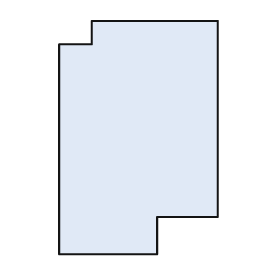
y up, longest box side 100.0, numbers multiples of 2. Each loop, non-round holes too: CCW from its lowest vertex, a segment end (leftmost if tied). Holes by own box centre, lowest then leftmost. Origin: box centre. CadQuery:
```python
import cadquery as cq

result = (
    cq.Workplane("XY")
    .moveTo(-34.0, -50.0)
    .lineTo(8.0, -50.0)
    .lineTo(8.0, -34.0)
    .lineTo(34.0, -34.0)
    .lineTo(34.0, 50.0)
    .lineTo(-20.0, 50.0)
    .lineTo(-20.0, 40.0)
    .lineTo(-34.0, 40.0)
    .close()
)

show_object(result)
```